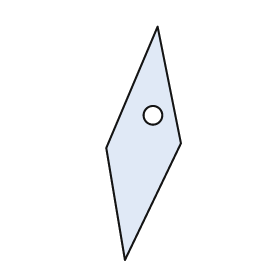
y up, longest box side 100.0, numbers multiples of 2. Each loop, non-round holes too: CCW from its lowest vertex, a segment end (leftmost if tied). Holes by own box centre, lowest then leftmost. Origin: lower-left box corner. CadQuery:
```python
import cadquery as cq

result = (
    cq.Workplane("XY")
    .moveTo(8.0, 0.0)
    .lineTo(32.0, 50.0)
    .lineTo(22.0, 100.0)
    .lineTo(0.0, 48.0)
    .close()
    .moveTo(20.0, 62.0)
    .circle(4.0)
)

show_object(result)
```